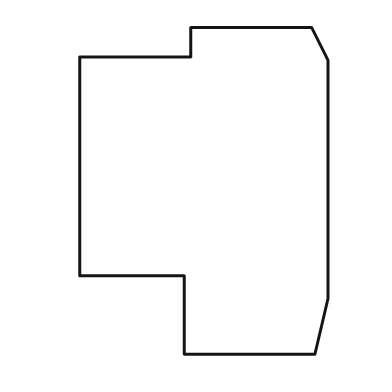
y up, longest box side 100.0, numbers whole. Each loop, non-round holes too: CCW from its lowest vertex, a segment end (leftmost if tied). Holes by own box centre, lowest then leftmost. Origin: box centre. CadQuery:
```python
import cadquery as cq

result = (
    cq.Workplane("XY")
    .moveTo(-6.0, -50.0)
    .lineTo(34.0, -50.0)
    .lineTo(38.0, -33.0)
    .lineTo(38.0, 40.0)
    .lineTo(33.0, 50.0)
    .lineTo(-4.0, 50.0)
    .lineTo(-4.0, 41.0)
    .lineTo(-38.0, 41.0)
    .lineTo(-38.0, -26.0)
    .lineTo(-6.0, -26.0)
    .close()
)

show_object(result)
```